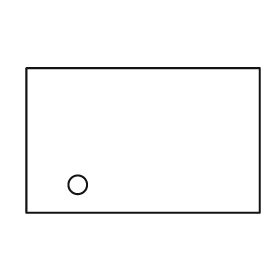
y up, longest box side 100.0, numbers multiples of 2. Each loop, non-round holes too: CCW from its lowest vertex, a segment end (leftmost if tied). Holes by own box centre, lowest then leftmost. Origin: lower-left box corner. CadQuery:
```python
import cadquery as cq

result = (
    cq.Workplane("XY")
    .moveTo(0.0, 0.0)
    .lineTo(100.0, 0.0)
    .lineTo(100.0, 62.0)
    .lineTo(0.0, 62.0)
    .close()
    .moveTo(22.0, 12.0)
    .circle(4.0)
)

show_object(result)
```